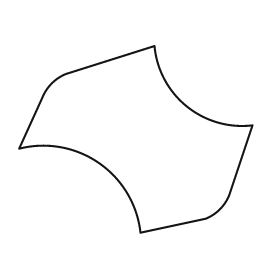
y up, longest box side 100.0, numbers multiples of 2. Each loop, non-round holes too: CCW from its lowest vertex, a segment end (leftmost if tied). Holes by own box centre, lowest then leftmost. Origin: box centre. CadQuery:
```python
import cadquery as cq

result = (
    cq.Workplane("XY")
    .moveTo(2.0, -40.0)
    .lineTo(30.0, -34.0)
    .threePointArc((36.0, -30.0), (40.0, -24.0))
    .lineTo(50.0, 6.0)
    .threePointArc((22.0, 14.0), (8.0, 40.0))
    .lineTo(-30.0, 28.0)
    .threePointArc((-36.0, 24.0), (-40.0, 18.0))
    .lineTo(-50.0, -4.0)
    .threePointArc((-16.0, -10.0), (2.0, -40.0))
    .close()
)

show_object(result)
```